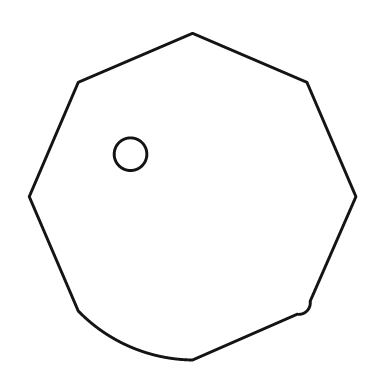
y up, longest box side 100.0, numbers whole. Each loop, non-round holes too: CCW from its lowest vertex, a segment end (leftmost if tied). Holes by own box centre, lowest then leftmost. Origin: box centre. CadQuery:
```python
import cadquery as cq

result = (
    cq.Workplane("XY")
    .moveTo(0.0, -50.0)
    .lineTo(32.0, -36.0)
    .threePointArc((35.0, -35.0), (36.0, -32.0))
    .lineTo(50.0, 0.0)
    .lineTo(35.0, 35.0)
    .lineTo(0.0, 50.0)
    .lineTo(-35.0, 35.0)
    .lineTo(-50.0, 0.0)
    .lineTo(-35.0, -35.0)
    .threePointArc((-19.0, -46.0), (0.0, -50.0))
    .close()
    .moveTo(-19.0, 13.0)
    .circle(5.0)
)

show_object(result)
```